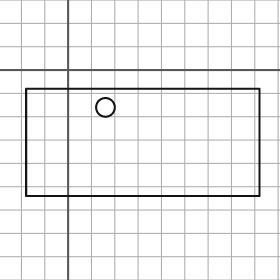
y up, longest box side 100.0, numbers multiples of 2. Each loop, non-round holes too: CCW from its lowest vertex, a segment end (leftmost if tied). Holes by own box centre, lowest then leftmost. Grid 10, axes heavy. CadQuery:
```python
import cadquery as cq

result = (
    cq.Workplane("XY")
    .moveTo(-18.0, -54.0)
    .lineTo(82.0, -54.0)
    .lineTo(82.0, -8.0)
    .lineTo(-18.0, -8.0)
    .close()
    .moveTo(16.0, -16.0)
    .circle(4.0)
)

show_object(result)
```